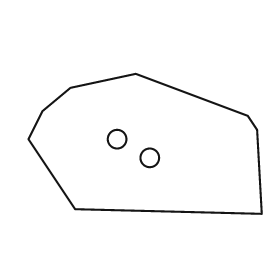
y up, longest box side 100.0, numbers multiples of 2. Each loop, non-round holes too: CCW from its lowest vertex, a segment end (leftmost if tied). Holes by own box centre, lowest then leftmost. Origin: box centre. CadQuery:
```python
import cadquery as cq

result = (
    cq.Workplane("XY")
    .moveTo(50.0, -30.0)
    .lineTo(48.0, 6.0)
    .lineTo(44.0, 12.0)
    .lineTo(-4.0, 30.0)
    .lineTo(-32.0, 24.0)
    .lineTo(-44.0, 14.0)
    .lineTo(-50.0, 2.0)
    .lineTo(-30.0, -28.0)
    .close()
    .moveTo(2.0, -6.0)
    .circle(4.0)
    .moveTo(-12.0, 2.0)
    .circle(4.0)
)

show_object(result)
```